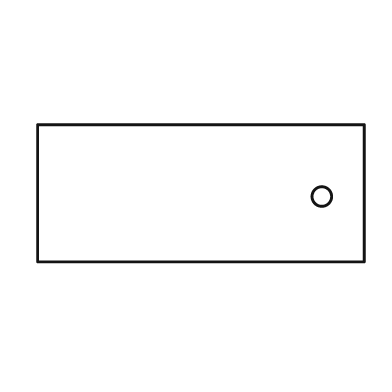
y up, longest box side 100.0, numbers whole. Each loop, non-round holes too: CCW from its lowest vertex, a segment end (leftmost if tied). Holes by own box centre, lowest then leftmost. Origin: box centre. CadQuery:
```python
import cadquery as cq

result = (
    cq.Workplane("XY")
    .moveTo(-50.0, -21.0)
    .lineTo(50.0, -21.0)
    .lineTo(50.0, 21.0)
    .lineTo(-50.0, 21.0)
    .close()
    .moveTo(37.0, -1.0)
    .circle(3.0)
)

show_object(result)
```